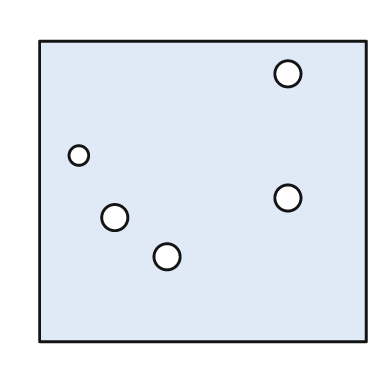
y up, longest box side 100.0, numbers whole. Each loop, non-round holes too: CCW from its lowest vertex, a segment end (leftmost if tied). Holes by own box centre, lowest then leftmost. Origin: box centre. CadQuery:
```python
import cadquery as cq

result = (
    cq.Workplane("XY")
    .moveTo(-50.0, -46.0)
    .lineTo(50.0, -46.0)
    .lineTo(50.0, 46.0)
    .lineTo(-50.0, 46.0)
    .close()
    .moveTo(-11.0, -20.0)
    .circle(4.0)
    .moveTo(-27.0, -8.0)
    .circle(4.0)
    .moveTo(26.0, -2.0)
    .circle(4.0)
    .moveTo(-38.0, 11.0)
    .circle(3.0)
    .moveTo(26.0, 36.0)
    .circle(4.0)
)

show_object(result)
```